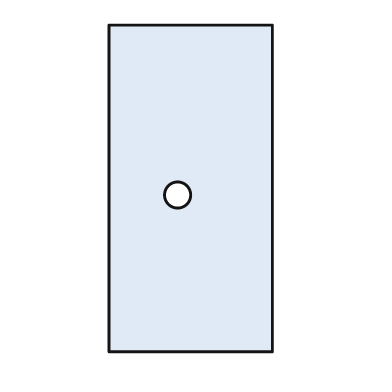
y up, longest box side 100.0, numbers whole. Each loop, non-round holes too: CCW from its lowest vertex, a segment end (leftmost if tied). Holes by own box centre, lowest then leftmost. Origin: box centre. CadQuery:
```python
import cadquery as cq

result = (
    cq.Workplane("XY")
    .moveTo(-25.0, -50.0)
    .lineTo(25.0, -50.0)
    .lineTo(25.0, 50.0)
    .lineTo(-25.0, 50.0)
    .close()
    .moveTo(-4.0, -2.0)
    .circle(4.0)
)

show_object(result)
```